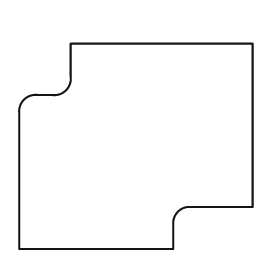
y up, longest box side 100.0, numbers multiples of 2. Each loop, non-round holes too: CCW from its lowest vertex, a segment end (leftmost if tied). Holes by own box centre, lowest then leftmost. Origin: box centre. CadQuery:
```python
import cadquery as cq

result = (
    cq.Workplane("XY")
    .moveTo(-50.0, -44.0)
    .lineTo(16.0, -44.0)
    .lineTo(16.0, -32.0)
    .threePointArc((18.0, -28.0), (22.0, -26.0))
    .lineTo(50.0, -26.0)
    .lineTo(50.0, 44.0)
    .lineTo(-28.0, 44.0)
    .lineTo(-28.0, 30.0)
    .threePointArc((-30.0, 24.0), (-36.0, 22.0))
    .lineTo(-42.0, 22.0)
    .threePointArc((-48.0, 20.0), (-50.0, 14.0))
    .close()
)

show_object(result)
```